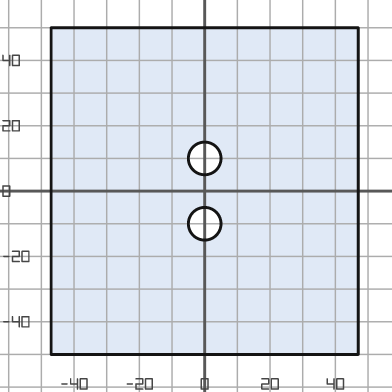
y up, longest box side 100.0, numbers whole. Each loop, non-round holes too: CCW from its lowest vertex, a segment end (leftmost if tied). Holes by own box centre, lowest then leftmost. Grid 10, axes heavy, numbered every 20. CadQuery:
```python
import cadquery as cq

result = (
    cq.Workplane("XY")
    .moveTo(-47.0, -50.0)
    .lineTo(47.0, -50.0)
    .lineTo(47.0, 50.0)
    .lineTo(-47.0, 50.0)
    .close()
    .moveTo(0.0, -10.0)
    .circle(5.0)
    .moveTo(0.0, 10.0)
    .circle(5.0)
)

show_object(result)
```